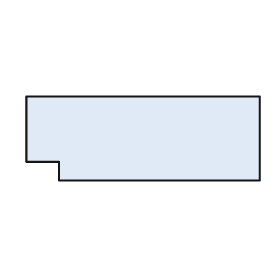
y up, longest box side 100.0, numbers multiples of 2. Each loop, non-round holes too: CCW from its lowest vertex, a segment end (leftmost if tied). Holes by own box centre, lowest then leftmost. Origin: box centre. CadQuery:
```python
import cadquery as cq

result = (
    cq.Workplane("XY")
    .moveTo(-36.0, -18.0)
    .lineTo(50.0, -18.0)
    .lineTo(50.0, 18.0)
    .lineTo(-50.0, 18.0)
    .lineTo(-50.0, -10.0)
    .lineTo(-36.0, -10.0)
    .close()
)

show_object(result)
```